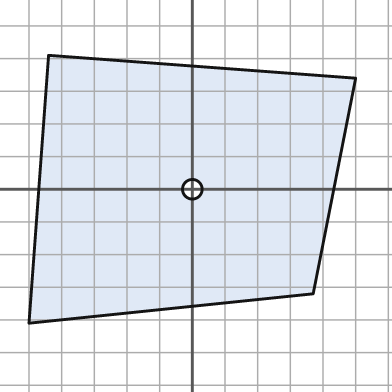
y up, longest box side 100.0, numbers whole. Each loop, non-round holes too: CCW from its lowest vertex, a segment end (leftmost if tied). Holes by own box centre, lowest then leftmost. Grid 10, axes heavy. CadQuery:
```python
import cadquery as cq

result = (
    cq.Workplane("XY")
    .moveTo(-50.0, -41.0)
    .lineTo(37.0, -32.0)
    .lineTo(50.0, 34.0)
    .lineTo(-44.0, 41.0)
    .close()
    .moveTo(0.0, 0.0)
    .circle(3.0)
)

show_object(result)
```